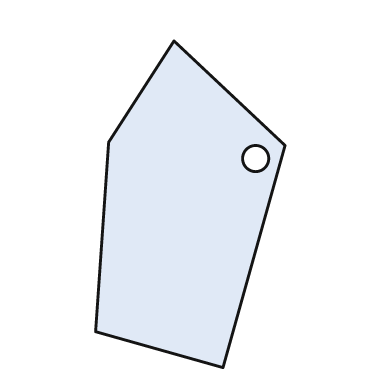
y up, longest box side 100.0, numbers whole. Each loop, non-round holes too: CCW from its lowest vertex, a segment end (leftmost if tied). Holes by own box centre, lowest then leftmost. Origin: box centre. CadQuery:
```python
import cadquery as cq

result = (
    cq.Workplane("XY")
    .moveTo(10.0, -50.0)
    .lineTo(29.0, 18.0)
    .lineTo(-5.0, 50.0)
    .lineTo(-25.0, 19.0)
    .lineTo(-29.0, -39.0)
    .close()
    .moveTo(20.0, 14.0)
    .circle(4.0)
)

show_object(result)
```